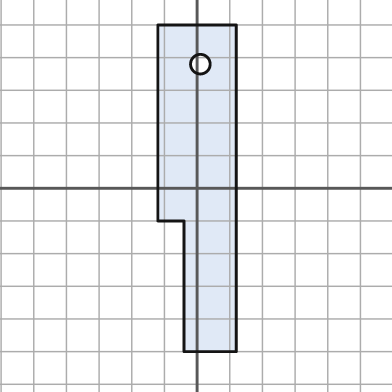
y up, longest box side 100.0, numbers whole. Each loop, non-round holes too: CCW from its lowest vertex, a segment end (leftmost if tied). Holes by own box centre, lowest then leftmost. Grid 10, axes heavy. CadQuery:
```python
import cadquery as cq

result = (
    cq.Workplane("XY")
    .moveTo(-4.0, -50.0)
    .lineTo(12.0, -50.0)
    .lineTo(12.0, 50.0)
    .lineTo(-12.0, 50.0)
    .lineTo(-12.0, -10.0)
    .lineTo(-4.0, -10.0)
    .close()
    .moveTo(1.0, 38.0)
    .circle(3.0)
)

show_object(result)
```